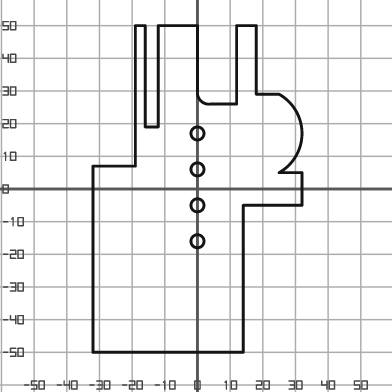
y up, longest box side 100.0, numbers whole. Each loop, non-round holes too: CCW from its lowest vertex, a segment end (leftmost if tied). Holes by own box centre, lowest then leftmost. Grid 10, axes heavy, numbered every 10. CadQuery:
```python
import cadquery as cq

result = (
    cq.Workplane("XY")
    .moveTo(-32.0, -50.0)
    .lineTo(14.0, -50.0)
    .lineTo(14.0, -5.0)
    .lineTo(32.0, -5.0)
    .lineTo(32.0, 5.0)
    .lineTo(25.0, 5.0)
    .threePointArc((32.0, 17.0), (25.0, 29.0))
    .lineTo(18.0, 29.0)
    .lineTo(18.0, 50.0)
    .lineTo(12.0, 50.0)
    .lineTo(12.0, 26.0)
    .lineTo(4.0, 26.0)
    .threePointArc((1.0, 27.0), (0.0, 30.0))
    .lineTo(0.0, 50.0)
    .lineTo(-12.0, 50.0)
    .lineTo(-12.0, 19.0)
    .lineTo(-16.0, 19.0)
    .lineTo(-16.0, 50.0)
    .lineTo(-19.0, 50.0)
    .lineTo(-19.0, 7.0)
    .lineTo(-32.0, 7.0)
    .close()
    .moveTo(0.0, -16.0)
    .circle(2.0)
    .moveTo(0.0, -5.0)
    .circle(2.0)
    .moveTo(0.0, 6.0)
    .circle(2.0)
    .moveTo(0.0, 17.0)
    .circle(2.0)
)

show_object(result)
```